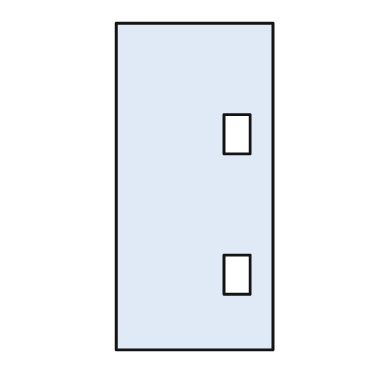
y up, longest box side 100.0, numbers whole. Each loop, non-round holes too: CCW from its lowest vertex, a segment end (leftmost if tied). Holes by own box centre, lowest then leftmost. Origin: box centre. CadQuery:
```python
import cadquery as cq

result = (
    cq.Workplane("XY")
    .moveTo(-24.0, -50.0)
    .lineTo(24.0, -50.0)
    .lineTo(24.0, 50.0)
    .lineTo(-24.0, 50.0)
    .close()
    .moveTo(9.0, -33.0)
    .lineTo(17.0, -33.0)
    .lineTo(17.0, -21.0)
    .lineTo(9.0, -21.0)
    .close()
    .moveTo(9.0, 10.0)
    .lineTo(17.0, 10.0)
    .lineTo(17.0, 22.0)
    .lineTo(9.0, 22.0)
    .close()
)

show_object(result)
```